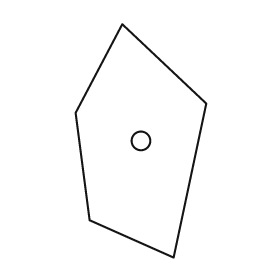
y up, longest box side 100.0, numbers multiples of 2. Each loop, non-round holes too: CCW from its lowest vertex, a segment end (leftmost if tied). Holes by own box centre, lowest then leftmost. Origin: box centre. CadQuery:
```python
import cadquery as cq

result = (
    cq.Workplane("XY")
    .moveTo(14.0, -50.0)
    .lineTo(28.0, 16.0)
    .lineTo(-8.0, 50.0)
    .lineTo(-28.0, 12.0)
    .lineTo(-22.0, -34.0)
    .close()
    .moveTo(0.0, 0.0)
    .circle(4.0)
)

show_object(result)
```